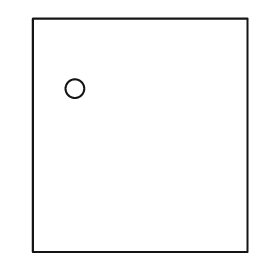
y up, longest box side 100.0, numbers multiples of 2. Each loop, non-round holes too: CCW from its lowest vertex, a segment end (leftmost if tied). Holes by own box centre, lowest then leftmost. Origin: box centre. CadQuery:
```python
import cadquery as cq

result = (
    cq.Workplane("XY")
    .moveTo(-46.0, -50.0)
    .lineTo(46.0, -50.0)
    .lineTo(46.0, 50.0)
    .lineTo(-46.0, 50.0)
    .close()
    .moveTo(-28.0, 20.0)
    .circle(4.0)
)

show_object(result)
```